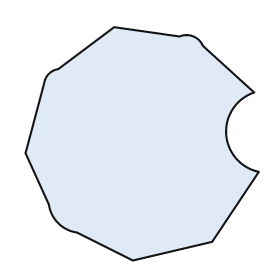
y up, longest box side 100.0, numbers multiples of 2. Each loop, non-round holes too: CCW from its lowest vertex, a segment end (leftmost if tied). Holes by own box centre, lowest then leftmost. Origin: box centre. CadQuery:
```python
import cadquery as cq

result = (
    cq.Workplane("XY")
    .moveTo(-4.0, -50.0)
    .lineTo(30.0, -42.0)
    .lineTo(50.0, -12.0)
    .threePointArc((36.0, 4.0), (48.0, 22.0))
    .lineTo(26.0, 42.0)
    .threePointArc((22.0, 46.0), (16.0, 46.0))
    .lineTo(-12.0, 50.0)
    .lineTo(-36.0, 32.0)
    .threePointArc((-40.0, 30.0), (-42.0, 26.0))
    .lineTo(-50.0, -4.0)
    .lineTo(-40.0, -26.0)
    .threePointArc((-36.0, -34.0), (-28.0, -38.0))
    .close()
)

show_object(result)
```